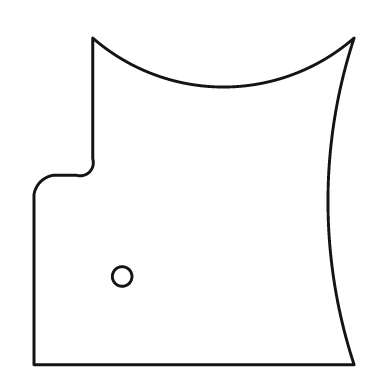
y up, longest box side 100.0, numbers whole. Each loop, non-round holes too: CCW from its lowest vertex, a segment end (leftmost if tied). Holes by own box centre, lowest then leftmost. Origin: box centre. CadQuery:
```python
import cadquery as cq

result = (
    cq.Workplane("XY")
    .moveTo(-49.0, -50.0)
    .lineTo(49.0, -50.0)
    .threePointArc((41.0, 0.0), (49.0, 50.0))
    .threePointArc((9.0, 35.0), (-31.0, 50.0))
    .lineTo(-31.0, 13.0)
    .threePointArc((-32.0, 9.0), (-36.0, 8.0))
    .lineTo(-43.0, 8.0)
    .threePointArc((-47.0, 6.0), (-49.0, 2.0))
    .close()
    .moveTo(-22.0, -23.0)
    .circle(3.0)
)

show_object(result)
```